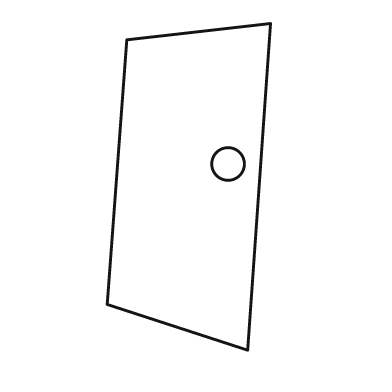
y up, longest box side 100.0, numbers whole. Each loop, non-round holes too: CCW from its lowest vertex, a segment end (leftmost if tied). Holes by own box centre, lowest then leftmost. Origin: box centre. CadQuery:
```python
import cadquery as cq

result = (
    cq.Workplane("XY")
    .moveTo(18.0, -50.0)
    .lineTo(25.0, 50.0)
    .lineTo(-19.0, 45.0)
    .lineTo(-25.0, -36.0)
    .close()
    .moveTo(12.0, 7.0)
    .circle(5.0)
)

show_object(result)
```